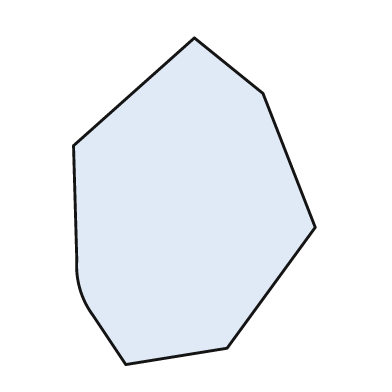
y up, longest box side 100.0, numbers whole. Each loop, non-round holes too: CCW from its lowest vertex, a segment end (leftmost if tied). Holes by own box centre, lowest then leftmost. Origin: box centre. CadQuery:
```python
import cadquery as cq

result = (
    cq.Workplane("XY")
    .moveTo(-21.0, -50.0)
    .lineTo(10.0, -45.0)
    .lineTo(37.0, -8.0)
    .lineTo(21.0, 33.0)
    .lineTo(0.0, 50.0)
    .lineTo(-37.0, 17.0)
    .lineTo(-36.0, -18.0)
    .threePointArc((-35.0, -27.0), (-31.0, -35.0))
    .close()
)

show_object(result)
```